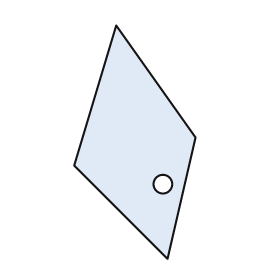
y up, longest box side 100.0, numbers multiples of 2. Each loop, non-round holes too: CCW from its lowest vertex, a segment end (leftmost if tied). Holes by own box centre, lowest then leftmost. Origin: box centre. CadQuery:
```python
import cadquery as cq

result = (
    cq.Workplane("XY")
    .moveTo(14.0, -50.0)
    .lineTo(26.0, 2.0)
    .lineTo(-8.0, 50.0)
    .lineTo(-26.0, -10.0)
    .close()
    .moveTo(12.0, -18.0)
    .circle(4.0)
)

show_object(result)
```